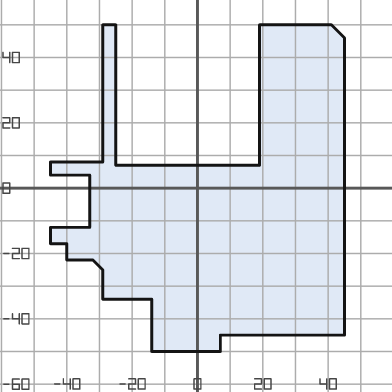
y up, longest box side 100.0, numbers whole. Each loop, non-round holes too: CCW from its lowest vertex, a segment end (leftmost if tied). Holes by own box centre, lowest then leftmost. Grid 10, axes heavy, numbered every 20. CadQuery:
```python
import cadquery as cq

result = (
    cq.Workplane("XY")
    .moveTo(-14.0, -50.0)
    .lineTo(7.0, -50.0)
    .lineTo(7.0, -45.0)
    .lineTo(45.0, -45.0)
    .lineTo(45.0, 46.0)
    .lineTo(41.0, 50.0)
    .lineTo(19.0, 50.0)
    .lineTo(19.0, 7.0)
    .lineTo(-25.0, 7.0)
    .lineTo(-25.0, 50.0)
    .lineTo(-29.0, 50.0)
    .lineTo(-29.0, 8.0)
    .lineTo(-45.0, 8.0)
    .lineTo(-45.0, 4.0)
    .lineTo(-33.0, 4.0)
    .lineTo(-33.0, -12.0)
    .lineTo(-45.0, -12.0)
    .lineTo(-45.0, -17.0)
    .lineTo(-40.0, -17.0)
    .lineTo(-40.0, -22.0)
    .lineTo(-32.0, -22.0)
    .lineTo(-29.0, -25.0)
    .lineTo(-29.0, -34.0)
    .lineTo(-14.0, -34.0)
    .close()
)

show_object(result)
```